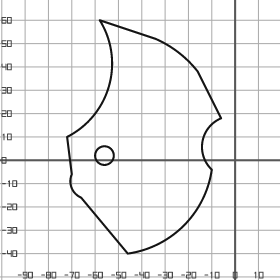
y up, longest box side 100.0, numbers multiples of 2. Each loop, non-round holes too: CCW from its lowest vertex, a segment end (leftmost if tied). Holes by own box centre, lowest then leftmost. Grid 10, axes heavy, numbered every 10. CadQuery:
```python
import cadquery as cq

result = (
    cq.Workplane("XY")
    .moveTo(-46.0, -40.0)
    .threePointArc((-22.0, -28.0), (-10.0, -4.0))
    .threePointArc((-14.0, 8.0), (-6.0, 18.0))
    .lineTo(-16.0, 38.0)
    .threePointArc((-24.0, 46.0), (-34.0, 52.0))
    .lineTo(-58.0, 60.0)
    .threePointArc((-54.0, 32.0), (-72.0, 10.0))
    .lineTo(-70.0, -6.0)
    .threePointArc((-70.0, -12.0), (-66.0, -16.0))
    .close()
    .moveTo(-56.0, 2.0)
    .circle(4.0)
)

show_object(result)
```